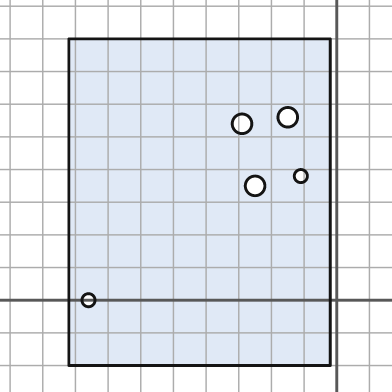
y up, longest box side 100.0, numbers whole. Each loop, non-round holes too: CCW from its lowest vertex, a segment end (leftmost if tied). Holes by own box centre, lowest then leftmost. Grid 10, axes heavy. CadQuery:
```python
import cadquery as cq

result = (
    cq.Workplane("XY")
    .moveTo(-82.0, -20.0)
    .lineTo(-2.0, -20.0)
    .lineTo(-2.0, 80.0)
    .lineTo(-82.0, 80.0)
    .close()
    .moveTo(-76.0, 0.0)
    .circle(2.0)
    .moveTo(-25.0, 35.0)
    .circle(3.0)
    .moveTo(-11.0, 38.0)
    .circle(2.0)
    .moveTo(-29.0, 54.0)
    .circle(3.0)
    .moveTo(-15.0, 56.0)
    .circle(3.0)
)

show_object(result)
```